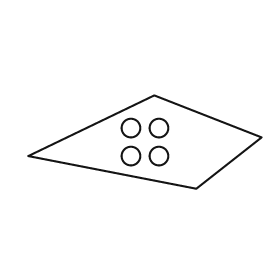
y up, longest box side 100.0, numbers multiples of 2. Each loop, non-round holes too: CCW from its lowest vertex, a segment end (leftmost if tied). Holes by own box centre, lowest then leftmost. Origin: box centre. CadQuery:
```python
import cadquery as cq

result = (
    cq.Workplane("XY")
    .moveTo(22.0, -20.0)
    .lineTo(50.0, 2.0)
    .lineTo(4.0, 20.0)
    .lineTo(-50.0, -6.0)
    .close()
    .moveTo(-6.0, -6.0)
    .circle(4.0)
    .moveTo(6.0, -6.0)
    .circle(4.0)
    .moveTo(-6.0, 6.0)
    .circle(4.0)
    .moveTo(6.0, 6.0)
    .circle(4.0)
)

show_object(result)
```